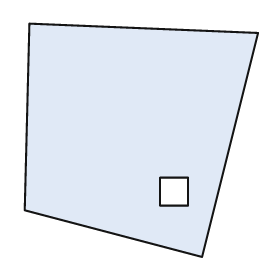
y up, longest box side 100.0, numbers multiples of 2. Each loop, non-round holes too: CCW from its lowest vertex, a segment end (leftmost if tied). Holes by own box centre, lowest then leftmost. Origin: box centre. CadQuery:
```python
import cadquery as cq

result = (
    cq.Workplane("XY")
    .moveTo(26.0, -50.0)
    .lineTo(50.0, 46.0)
    .lineTo(-48.0, 50.0)
    .lineTo(-50.0, -30.0)
    .close()
    .moveTo(8.0, -28.0)
    .lineTo(20.0, -28.0)
    .lineTo(20.0, -16.0)
    .lineTo(8.0, -16.0)
    .close()
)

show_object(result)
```